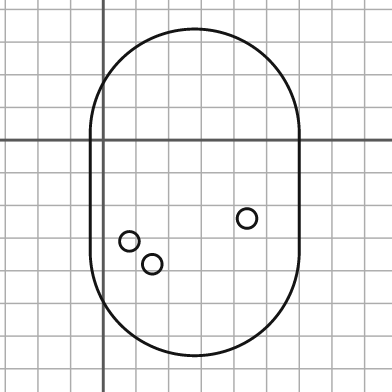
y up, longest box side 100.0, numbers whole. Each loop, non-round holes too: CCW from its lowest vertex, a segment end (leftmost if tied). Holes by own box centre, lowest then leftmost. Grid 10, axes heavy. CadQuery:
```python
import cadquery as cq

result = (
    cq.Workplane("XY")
    .moveTo(-4.0, -34.0)
    .threePointArc((28.0, -66.0), (60.0, -34.0))
    .lineTo(60.0, 2.0)
    .threePointArc((28.0, 34.0), (-4.0, 2.0))
    .close()
    .moveTo(15.0, -38.0)
    .circle(3.0)
    .moveTo(8.0, -31.0)
    .circle(3.0)
    .moveTo(44.0, -24.0)
    .circle(3.0)
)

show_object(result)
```